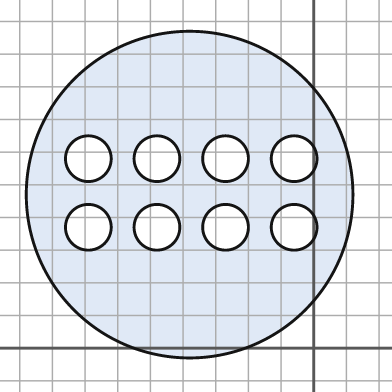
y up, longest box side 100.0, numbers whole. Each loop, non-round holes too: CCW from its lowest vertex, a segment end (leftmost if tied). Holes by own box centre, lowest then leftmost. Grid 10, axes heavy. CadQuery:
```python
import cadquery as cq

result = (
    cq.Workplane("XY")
    .moveTo(-38.0, 47.0)
    .circle(50.0)
    .moveTo(-69.0, 37.0)
    .circle(7.0)
    .moveTo(-48.0, 37.0)
    .circle(7.0)
    .moveTo(-27.0, 37.0)
    .circle(7.0)
    .moveTo(-6.0, 37.0)
    .circle(7.0)
    .moveTo(-69.0, 58.0)
    .circle(7.0)
    .moveTo(-48.0, 58.0)
    .circle(7.0)
    .moveTo(-27.0, 58.0)
    .circle(7.0)
    .moveTo(-6.0, 58.0)
    .circle(7.0)
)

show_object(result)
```